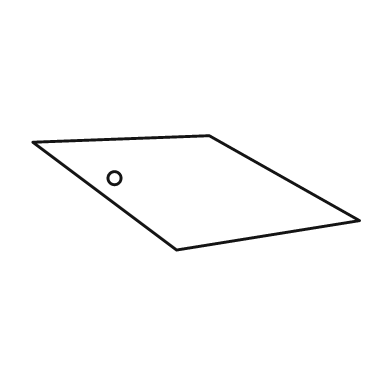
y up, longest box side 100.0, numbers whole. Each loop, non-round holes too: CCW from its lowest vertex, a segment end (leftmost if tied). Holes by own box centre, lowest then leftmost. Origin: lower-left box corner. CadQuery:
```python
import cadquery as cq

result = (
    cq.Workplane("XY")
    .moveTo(44.0, 0.0)
    .lineTo(100.0, 9.0)
    .lineTo(54.0, 35.0)
    .lineTo(0.0, 33.0)
    .close()
    .moveTo(25.0, 22.0)
    .circle(2.0)
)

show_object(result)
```